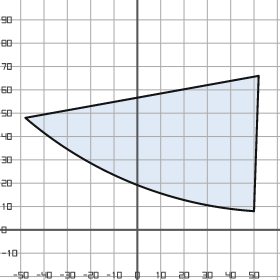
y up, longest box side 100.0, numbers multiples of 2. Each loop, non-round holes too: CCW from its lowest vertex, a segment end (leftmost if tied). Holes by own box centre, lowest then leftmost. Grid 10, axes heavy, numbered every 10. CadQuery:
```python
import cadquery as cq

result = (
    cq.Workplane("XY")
    .moveTo(50.0, 8.0)
    .lineTo(52.0, 66.0)
    .lineTo(-48.0, 48.0)
    .threePointArc((-2.0, 20.0), (50.0, 8.0))
    .close()
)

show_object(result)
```